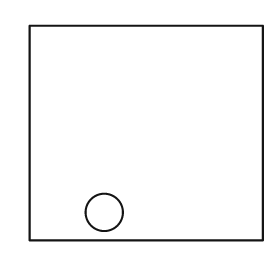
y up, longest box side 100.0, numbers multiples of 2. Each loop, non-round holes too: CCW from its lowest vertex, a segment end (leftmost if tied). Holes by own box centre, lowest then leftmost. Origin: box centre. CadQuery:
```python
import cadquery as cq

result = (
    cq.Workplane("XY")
    .moveTo(-50.0, -46.0)
    .lineTo(50.0, -46.0)
    .lineTo(50.0, 46.0)
    .lineTo(-50.0, 46.0)
    .close()
    .moveTo(-18.0, -34.0)
    .circle(8.0)
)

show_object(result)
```